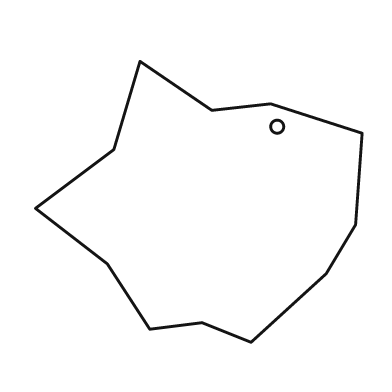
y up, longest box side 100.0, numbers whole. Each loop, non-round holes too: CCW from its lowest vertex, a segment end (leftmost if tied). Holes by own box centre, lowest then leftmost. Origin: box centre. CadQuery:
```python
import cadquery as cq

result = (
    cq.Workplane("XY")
    .moveTo(16.0, -43.0)
    .lineTo(39.0, -22.0)
    .lineTo(48.0, -7.0)
    .lineTo(50.0, 21.0)
    .lineTo(22.0, 30.0)
    .lineTo(4.0, 28.0)
    .lineTo(-18.0, 43.0)
    .lineTo(-26.0, 16.0)
    .lineTo(-50.0, -2.0)
    .lineTo(-28.0, -19.0)
    .lineTo(-15.0, -39.0)
    .lineTo(1.0, -37.0)
    .close()
    .moveTo(24.0, 23.0)
    .circle(2.0)
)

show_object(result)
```